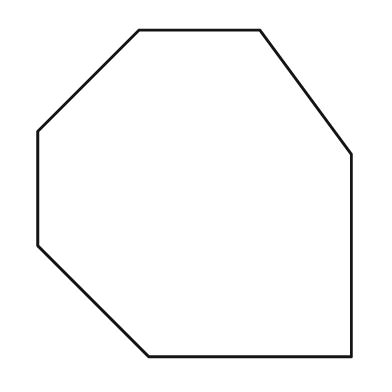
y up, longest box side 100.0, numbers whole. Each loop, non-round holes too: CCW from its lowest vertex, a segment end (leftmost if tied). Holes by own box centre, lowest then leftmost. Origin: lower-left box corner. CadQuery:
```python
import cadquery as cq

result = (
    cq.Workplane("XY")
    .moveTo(34.0, 0.0)
    .lineTo(96.0, 0.0)
    .lineTo(96.0, 62.0)
    .lineTo(68.0, 100.0)
    .lineTo(31.0, 100.0)
    .lineTo(0.0, 69.0)
    .lineTo(0.0, 34.0)
    .close()
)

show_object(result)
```